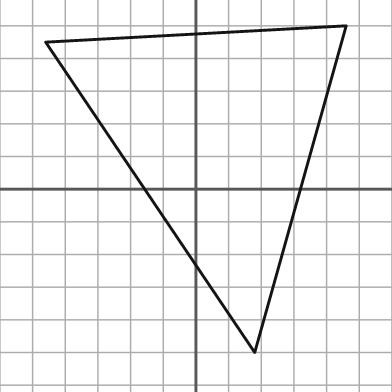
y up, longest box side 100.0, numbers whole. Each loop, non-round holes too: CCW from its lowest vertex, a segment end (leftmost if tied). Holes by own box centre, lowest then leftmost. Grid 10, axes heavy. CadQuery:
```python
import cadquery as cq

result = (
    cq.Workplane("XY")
    .moveTo(18.0, -50.0)
    .lineTo(46.0, 50.0)
    .lineTo(-46.0, 45.0)
    .close()
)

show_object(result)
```